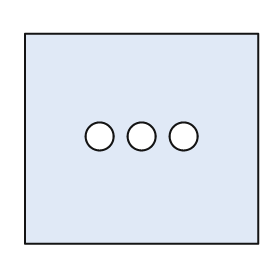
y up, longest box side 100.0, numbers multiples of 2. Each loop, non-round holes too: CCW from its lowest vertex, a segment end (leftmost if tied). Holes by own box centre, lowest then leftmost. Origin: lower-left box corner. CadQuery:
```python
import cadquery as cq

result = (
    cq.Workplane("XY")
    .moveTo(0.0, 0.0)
    .lineTo(100.0, 0.0)
    .lineTo(100.0, 90.0)
    .lineTo(0.0, 90.0)
    .close()
    .moveTo(32.0, 46.0)
    .circle(6.0)
    .moveTo(50.0, 46.0)
    .circle(6.0)
    .moveTo(68.0, 46.0)
    .circle(6.0)
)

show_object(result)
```